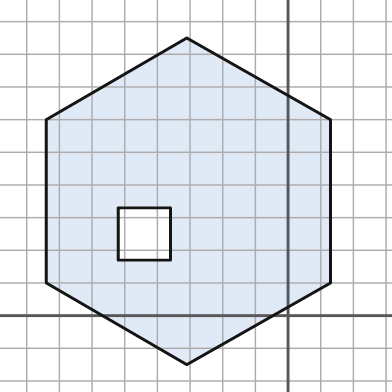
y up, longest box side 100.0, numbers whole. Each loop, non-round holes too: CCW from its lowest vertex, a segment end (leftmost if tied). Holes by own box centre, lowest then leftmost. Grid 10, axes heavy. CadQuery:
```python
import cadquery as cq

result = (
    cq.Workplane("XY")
    .moveTo(-31.0, -15.0)
    .lineTo(13.0, 10.0)
    .lineTo(13.0, 60.0)
    .lineTo(-31.0, 85.0)
    .lineTo(-74.0, 60.0)
    .lineTo(-74.0, 10.0)
    .close()
    .moveTo(-52.0, 17.0)
    .lineTo(-36.0, 17.0)
    .lineTo(-36.0, 33.0)
    .lineTo(-52.0, 33.0)
    .close()
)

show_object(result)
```